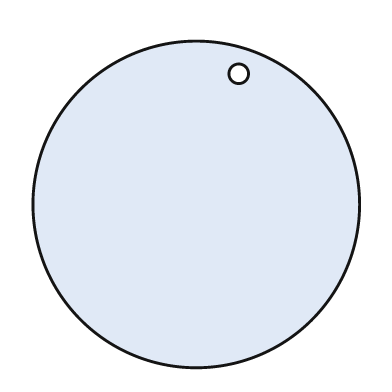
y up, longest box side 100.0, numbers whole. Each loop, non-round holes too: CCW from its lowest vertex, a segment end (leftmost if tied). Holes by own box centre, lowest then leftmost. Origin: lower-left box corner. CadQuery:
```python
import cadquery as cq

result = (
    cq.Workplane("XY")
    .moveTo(50.0, 50.0)
    .circle(50.0)
    .moveTo(63.0, 90.0)
    .circle(3.0)
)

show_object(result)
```